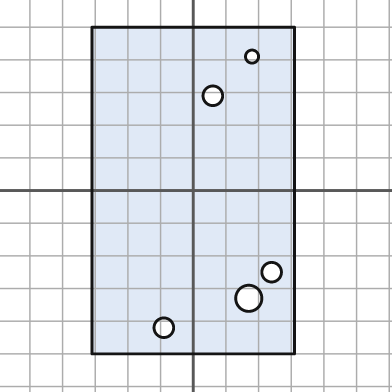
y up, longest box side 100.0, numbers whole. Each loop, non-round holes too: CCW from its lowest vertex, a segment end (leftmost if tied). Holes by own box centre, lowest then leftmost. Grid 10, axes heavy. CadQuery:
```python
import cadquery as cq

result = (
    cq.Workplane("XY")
    .moveTo(-31.0, -50.0)
    .lineTo(31.0, -50.0)
    .lineTo(31.0, 50.0)
    .lineTo(-31.0, 50.0)
    .close()
    .moveTo(-9.0, -42.0)
    .circle(3.0)
    .moveTo(17.0, -33.0)
    .circle(4.0)
    .moveTo(24.0, -25.0)
    .circle(3.0)
    .moveTo(6.0, 29.0)
    .circle(3.0)
    .moveTo(18.0, 41.0)
    .circle(2.0)
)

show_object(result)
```